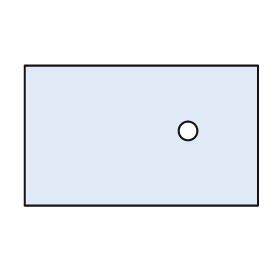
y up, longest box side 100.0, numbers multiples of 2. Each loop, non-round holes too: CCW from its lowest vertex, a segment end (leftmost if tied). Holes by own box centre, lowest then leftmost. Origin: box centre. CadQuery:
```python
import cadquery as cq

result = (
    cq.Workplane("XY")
    .moveTo(-50.0, -30.0)
    .lineTo(50.0, -30.0)
    .lineTo(50.0, 30.0)
    .lineTo(-50.0, 30.0)
    .close()
    .moveTo(20.0, 2.0)
    .circle(4.0)
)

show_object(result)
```